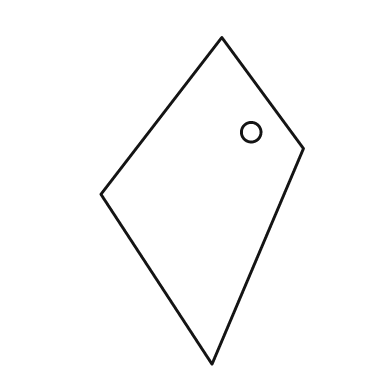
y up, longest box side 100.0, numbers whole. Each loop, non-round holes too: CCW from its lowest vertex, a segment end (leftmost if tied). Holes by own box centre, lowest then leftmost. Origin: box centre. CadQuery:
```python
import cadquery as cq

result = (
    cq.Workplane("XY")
    .moveTo(3.0, -50.0)
    .lineTo(31.0, 16.0)
    .lineTo(6.0, 50.0)
    .lineTo(-31.0, 2.0)
    .close()
    .moveTo(15.0, 21.0)
    .circle(3.0)
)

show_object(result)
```